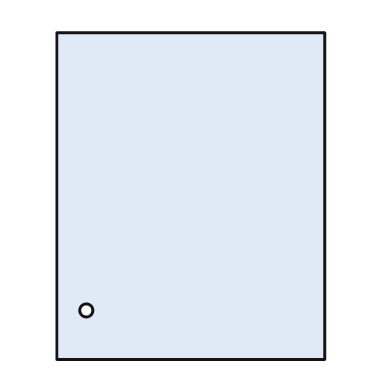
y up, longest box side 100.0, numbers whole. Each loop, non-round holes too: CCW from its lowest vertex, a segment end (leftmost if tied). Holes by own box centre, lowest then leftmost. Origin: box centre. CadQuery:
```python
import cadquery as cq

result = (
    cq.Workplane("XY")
    .moveTo(-41.0, -50.0)
    .lineTo(41.0, -50.0)
    .lineTo(41.0, 50.0)
    .lineTo(-41.0, 50.0)
    .close()
    .moveTo(-32.0, -35.0)
    .circle(2.0)
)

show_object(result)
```